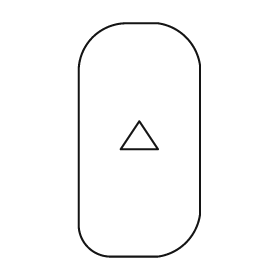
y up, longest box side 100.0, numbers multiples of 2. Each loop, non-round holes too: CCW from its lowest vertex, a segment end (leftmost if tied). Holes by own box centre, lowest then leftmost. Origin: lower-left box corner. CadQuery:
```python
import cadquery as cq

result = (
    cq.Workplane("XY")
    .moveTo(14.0, 0.0)
    .lineTo(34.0, 0.0)
    .threePointArc((46.0, 6.0), (52.0, 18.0))
    .lineTo(52.0, 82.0)
    .threePointArc((46.0, 94.0), (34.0, 100.0))
    .lineTo(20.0, 100.0)
    .threePointArc((6.0, 94.0), (0.0, 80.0))
    .lineTo(0.0, 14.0)
    .threePointArc((4.0, 4.0), (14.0, 0.0))
    .close()
    .moveTo(18.0, 46.0)
    .lineTo(34.0, 46.0)
    .lineTo(26.0, 58.0)
    .close()
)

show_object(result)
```